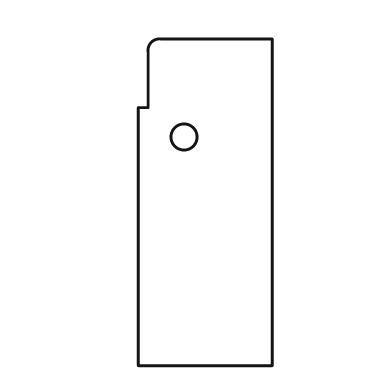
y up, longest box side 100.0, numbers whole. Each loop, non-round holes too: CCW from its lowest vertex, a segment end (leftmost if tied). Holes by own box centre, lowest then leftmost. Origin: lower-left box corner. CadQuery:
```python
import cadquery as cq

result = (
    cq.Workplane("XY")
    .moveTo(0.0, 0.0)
    .lineTo(41.0, 0.0)
    .lineTo(41.0, 100.0)
    .lineTo(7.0, 100.0)
    .threePointArc((4.0, 99.0), (3.0, 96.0))
    .lineTo(3.0, 79.0)
    .lineTo(0.0, 79.0)
    .close()
    .moveTo(14.0, 70.0)
    .circle(4.0)
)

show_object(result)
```